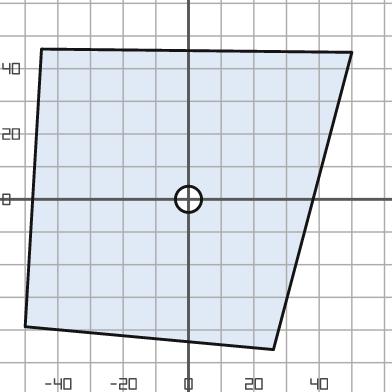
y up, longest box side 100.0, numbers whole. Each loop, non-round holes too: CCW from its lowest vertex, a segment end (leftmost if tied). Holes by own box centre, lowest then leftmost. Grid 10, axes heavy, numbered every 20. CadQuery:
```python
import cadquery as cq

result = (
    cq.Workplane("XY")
    .moveTo(26.0, -46.0)
    .lineTo(50.0, 45.0)
    .lineTo(-45.0, 46.0)
    .lineTo(-50.0, -39.0)
    .close()
    .moveTo(0.0, 0.0)
    .circle(4.0)
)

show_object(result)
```